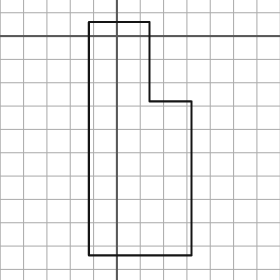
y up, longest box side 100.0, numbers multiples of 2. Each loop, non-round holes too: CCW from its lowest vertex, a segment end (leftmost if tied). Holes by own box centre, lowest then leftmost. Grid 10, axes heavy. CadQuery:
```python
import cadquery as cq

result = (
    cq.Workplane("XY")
    .moveTo(-12.0, -94.0)
    .lineTo(32.0, -94.0)
    .lineTo(32.0, -28.0)
    .lineTo(14.0, -28.0)
    .lineTo(14.0, 6.0)
    .lineTo(-12.0, 6.0)
    .close()
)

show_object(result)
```